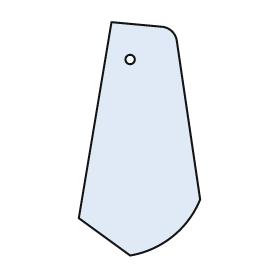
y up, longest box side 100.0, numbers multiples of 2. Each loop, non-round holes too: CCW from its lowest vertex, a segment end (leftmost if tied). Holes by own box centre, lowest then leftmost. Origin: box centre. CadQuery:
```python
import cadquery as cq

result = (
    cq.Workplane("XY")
    .moveTo(-4.0, -50.0)
    .threePointArc((14.0, -42.0), (26.0, -26.0))
    .lineTo(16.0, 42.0)
    .threePointArc((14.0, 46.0), (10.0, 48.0))
    .lineTo(-12.0, 50.0)
    .lineTo(-26.0, -34.0)
    .close()
    .moveTo(-4.0, 34.0)
    .circle(2.0)
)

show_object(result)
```